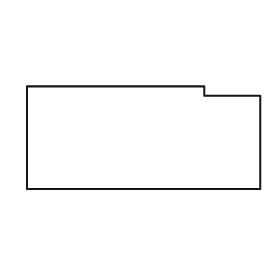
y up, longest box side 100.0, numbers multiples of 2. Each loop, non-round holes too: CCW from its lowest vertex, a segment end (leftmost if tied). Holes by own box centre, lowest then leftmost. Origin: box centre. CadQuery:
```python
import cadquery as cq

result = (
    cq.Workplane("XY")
    .moveTo(-50.0, -22.0)
    .lineTo(50.0, -22.0)
    .lineTo(50.0, 18.0)
    .lineTo(26.0, 18.0)
    .lineTo(26.0, 22.0)
    .lineTo(-50.0, 22.0)
    .close()
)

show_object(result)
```